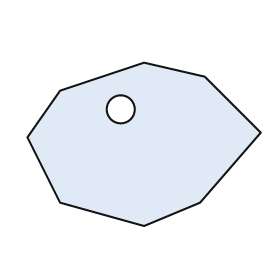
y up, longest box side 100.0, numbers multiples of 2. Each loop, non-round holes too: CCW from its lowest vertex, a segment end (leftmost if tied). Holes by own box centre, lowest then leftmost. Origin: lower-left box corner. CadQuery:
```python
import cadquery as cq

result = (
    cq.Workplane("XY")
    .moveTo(50.0, 0.0)
    .lineTo(74.0, 10.0)
    .lineTo(100.0, 40.0)
    .lineTo(76.0, 64.0)
    .lineTo(50.0, 70.0)
    .lineTo(14.0, 58.0)
    .lineTo(0.0, 38.0)
    .lineTo(14.0, 10.0)
    .close()
    .moveTo(40.0, 50.0)
    .circle(6.0)
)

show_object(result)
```